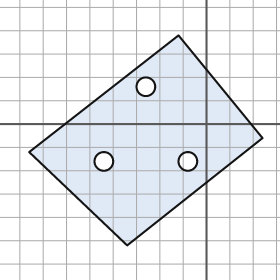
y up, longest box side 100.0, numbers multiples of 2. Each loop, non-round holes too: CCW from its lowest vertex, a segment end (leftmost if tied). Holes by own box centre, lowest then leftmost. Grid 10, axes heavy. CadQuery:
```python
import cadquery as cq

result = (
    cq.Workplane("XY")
    .moveTo(-34.0, -52.0)
    .lineTo(24.0, -6.0)
    .lineTo(-12.0, 38.0)
    .lineTo(-76.0, -12.0)
    .close()
    .moveTo(-44.0, -16.0)
    .circle(4.0)
    .moveTo(-8.0, -16.0)
    .circle(4.0)
    .moveTo(-26.0, 16.0)
    .circle(4.0)
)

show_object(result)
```